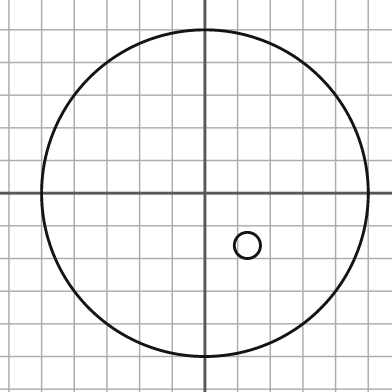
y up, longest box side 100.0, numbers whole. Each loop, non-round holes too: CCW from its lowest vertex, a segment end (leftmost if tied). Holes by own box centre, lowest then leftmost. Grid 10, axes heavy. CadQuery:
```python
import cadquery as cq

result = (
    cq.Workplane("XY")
    .moveTo(0.0, 0.0)
    .circle(50.0)
    .moveTo(13.0, -16.0)
    .circle(4.0)
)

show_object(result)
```